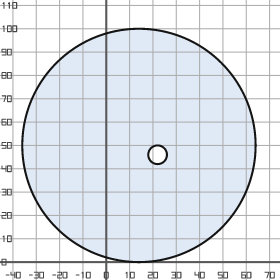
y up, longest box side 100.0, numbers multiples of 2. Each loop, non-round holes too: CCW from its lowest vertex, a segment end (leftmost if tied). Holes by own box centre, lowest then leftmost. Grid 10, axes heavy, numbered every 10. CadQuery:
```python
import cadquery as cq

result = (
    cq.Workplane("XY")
    .moveTo(14.0, 50.0)
    .circle(50.0)
    .moveTo(22.0, 46.0)
    .circle(4.0)
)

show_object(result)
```